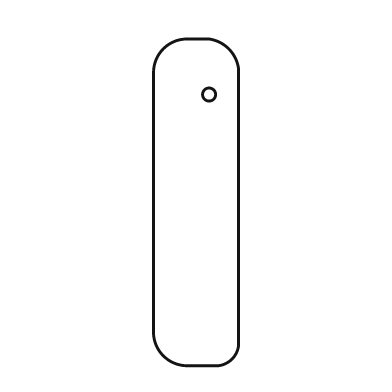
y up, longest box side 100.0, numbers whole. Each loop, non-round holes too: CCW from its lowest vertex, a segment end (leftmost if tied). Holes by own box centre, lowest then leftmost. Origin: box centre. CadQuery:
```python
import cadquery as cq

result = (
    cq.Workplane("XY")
    .moveTo(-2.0, -50.0)
    .lineTo(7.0, -50.0)
    .threePointArc((11.0, -48.0), (13.0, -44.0))
    .lineTo(13.0, 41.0)
    .threePointArc((10.0, 47.0), (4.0, 50.0))
    .lineTo(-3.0, 50.0)
    .threePointArc((-10.0, 47.0), (-13.0, 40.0))
    .lineTo(-13.0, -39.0)
    .threePointArc((-10.0, -47.0), (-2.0, -50.0))
    .close()
    .moveTo(4.0, 33.0)
    .circle(2.0)
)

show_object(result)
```